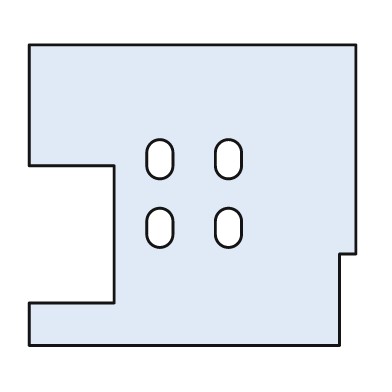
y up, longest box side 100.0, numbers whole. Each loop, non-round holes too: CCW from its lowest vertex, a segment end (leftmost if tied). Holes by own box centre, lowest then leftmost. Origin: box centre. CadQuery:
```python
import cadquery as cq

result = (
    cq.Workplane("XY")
    .moveTo(-50.0, -46.0)
    .lineTo(45.0, -46.0)
    .lineTo(45.0, -18.0)
    .lineTo(50.0, -18.0)
    .lineTo(50.0, 46.0)
    .lineTo(-50.0, 46.0)
    .lineTo(-50.0, 9.0)
    .lineTo(-24.0, 9.0)
    .lineTo(-24.0, -33.0)
    .lineTo(-50.0, -33.0)
    .close()
    .moveTo(-14.0, -12.0)
    .threePointArc((-10.0, -16.0), (-6.0, -12.0))
    .lineTo(-6.0, -8.0)
    .threePointArc((-10.0, -4.0), (-14.0, -8.0))
    .close()
    .moveTo(7.0, -12.0)
    .threePointArc((11.0, -16.0), (15.0, -12.0))
    .lineTo(15.0, -8.0)
    .threePointArc((11.0, -4.0), (7.0, -8.0))
    .close()
    .moveTo(-14.0, 9.0)
    .threePointArc((-10.0, 5.0), (-6.0, 9.0))
    .lineTo(-6.0, 13.0)
    .threePointArc((-10.0, 17.0), (-14.0, 13.0))
    .close()
    .moveTo(7.0, 9.0)
    .threePointArc((11.0, 5.0), (15.0, 9.0))
    .lineTo(15.0, 13.0)
    .threePointArc((11.0, 17.0), (7.0, 13.0))
    .close()
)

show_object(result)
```